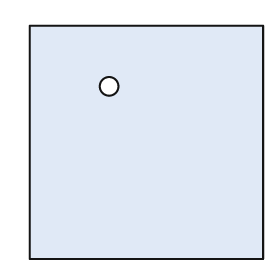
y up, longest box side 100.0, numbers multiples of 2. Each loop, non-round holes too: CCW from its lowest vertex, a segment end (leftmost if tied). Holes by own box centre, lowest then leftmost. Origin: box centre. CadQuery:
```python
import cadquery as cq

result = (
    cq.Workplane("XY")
    .moveTo(-50.0, -50.0)
    .lineTo(50.0, -50.0)
    .lineTo(50.0, 50.0)
    .lineTo(-50.0, 50.0)
    .close()
    .moveTo(-16.0, 24.0)
    .circle(4.0)
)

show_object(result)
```